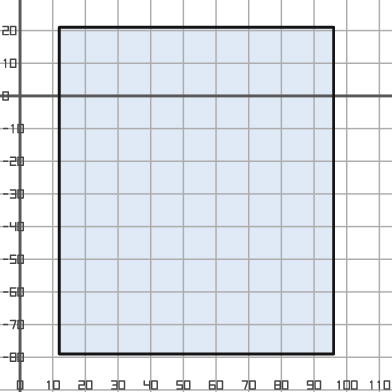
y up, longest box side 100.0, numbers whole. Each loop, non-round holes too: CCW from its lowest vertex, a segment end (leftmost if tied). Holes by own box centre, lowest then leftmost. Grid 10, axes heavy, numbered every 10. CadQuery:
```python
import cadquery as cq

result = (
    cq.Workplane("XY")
    .moveTo(12.0, -79.0)
    .lineTo(96.0, -79.0)
    .lineTo(96.0, 21.0)
    .lineTo(12.0, 21.0)
    .close()
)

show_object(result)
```